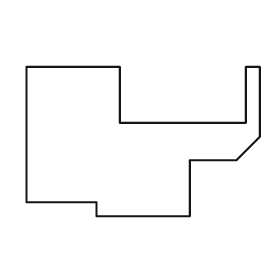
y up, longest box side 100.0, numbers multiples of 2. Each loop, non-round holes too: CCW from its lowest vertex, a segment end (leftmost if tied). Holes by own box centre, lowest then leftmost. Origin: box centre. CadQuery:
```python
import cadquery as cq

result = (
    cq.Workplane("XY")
    .moveTo(-20.0, -32.0)
    .lineTo(20.0, -32.0)
    .lineTo(20.0, -8.0)
    .lineTo(40.0, -8.0)
    .lineTo(50.0, 2.0)
    .lineTo(50.0, 32.0)
    .lineTo(44.0, 32.0)
    .lineTo(44.0, 8.0)
    .lineTo(-10.0, 8.0)
    .lineTo(-10.0, 32.0)
    .lineTo(-50.0, 32.0)
    .lineTo(-50.0, -26.0)
    .lineTo(-20.0, -26.0)
    .close()
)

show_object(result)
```